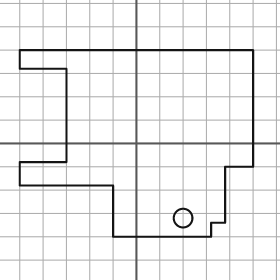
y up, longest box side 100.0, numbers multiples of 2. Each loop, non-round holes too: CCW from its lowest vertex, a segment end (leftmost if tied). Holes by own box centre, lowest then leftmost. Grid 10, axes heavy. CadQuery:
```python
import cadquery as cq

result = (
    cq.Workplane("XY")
    .moveTo(-10.0, -40.0)
    .lineTo(32.0, -40.0)
    .lineTo(32.0, -34.0)
    .lineTo(38.0, -34.0)
    .lineTo(38.0, -10.0)
    .lineTo(50.0, -10.0)
    .lineTo(50.0, 40.0)
    .lineTo(-50.0, 40.0)
    .lineTo(-50.0, 32.0)
    .lineTo(-30.0, 32.0)
    .lineTo(-30.0, -8.0)
    .lineTo(-50.0, -8.0)
    .lineTo(-50.0, -18.0)
    .lineTo(-10.0, -18.0)
    .close()
    .moveTo(20.0, -32.0)
    .circle(4.0)
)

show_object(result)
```